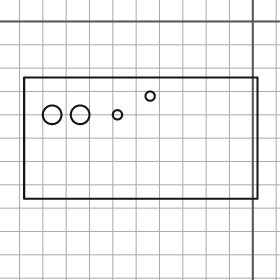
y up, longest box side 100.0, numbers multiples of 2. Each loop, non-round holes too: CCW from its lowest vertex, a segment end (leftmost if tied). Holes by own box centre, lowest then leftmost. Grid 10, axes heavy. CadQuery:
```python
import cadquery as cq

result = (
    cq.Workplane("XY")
    .moveTo(-98.0, -76.0)
    .lineTo(2.0, -76.0)
    .lineTo(2.0, -24.0)
    .lineTo(-98.0, -24.0)
    .close()
    .moveTo(-86.0, -40.0)
    .circle(4.0)
    .moveTo(-74.0, -40.0)
    .circle(4.0)
    .moveTo(-58.0, -40.0)
    .circle(2.0)
    .moveTo(-44.0, -32.0)
    .circle(2.0)
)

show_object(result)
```